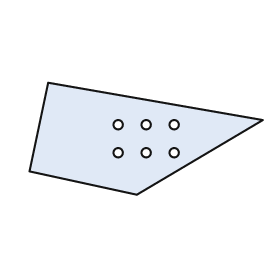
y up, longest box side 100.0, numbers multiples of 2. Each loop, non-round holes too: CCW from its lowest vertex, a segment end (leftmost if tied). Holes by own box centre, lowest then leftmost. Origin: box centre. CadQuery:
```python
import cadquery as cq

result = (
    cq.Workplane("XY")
    .moveTo(-4.0, -24.0)
    .lineTo(50.0, 8.0)
    .lineTo(-42.0, 24.0)
    .lineTo(-50.0, -14.0)
    .close()
    .moveTo(-12.0, -6.0)
    .circle(2.0)
    .moveTo(0.0, -6.0)
    .circle(2.0)
    .moveTo(12.0, -6.0)
    .circle(2.0)
    .moveTo(-12.0, 6.0)
    .circle(2.0)
    .moveTo(0.0, 6.0)
    .circle(2.0)
    .moveTo(12.0, 6.0)
    .circle(2.0)
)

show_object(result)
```